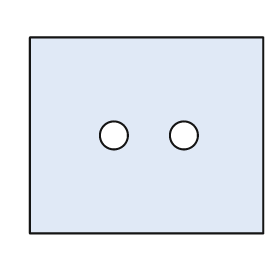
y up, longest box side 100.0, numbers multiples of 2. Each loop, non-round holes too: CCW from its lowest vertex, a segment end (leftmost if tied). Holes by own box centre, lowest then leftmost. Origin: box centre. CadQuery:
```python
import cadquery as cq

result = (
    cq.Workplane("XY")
    .moveTo(-50.0, -42.0)
    .lineTo(50.0, -42.0)
    .lineTo(50.0, 42.0)
    .lineTo(-50.0, 42.0)
    .close()
    .moveTo(-14.0, 0.0)
    .circle(6.0)
    .moveTo(16.0, 0.0)
    .circle(6.0)
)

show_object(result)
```